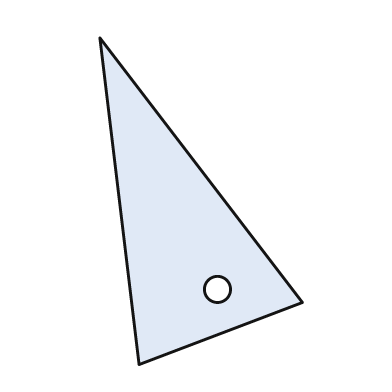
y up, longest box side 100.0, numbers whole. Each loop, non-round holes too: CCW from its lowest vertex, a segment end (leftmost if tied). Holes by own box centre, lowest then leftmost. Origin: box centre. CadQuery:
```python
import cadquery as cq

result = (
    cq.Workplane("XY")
    .moveTo(-19.0, -50.0)
    .lineTo(31.0, -31.0)
    .lineTo(-31.0, 50.0)
    .close()
    .moveTo(5.0, -27.0)
    .circle(4.0)
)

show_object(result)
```